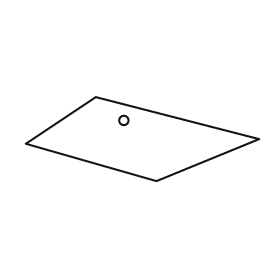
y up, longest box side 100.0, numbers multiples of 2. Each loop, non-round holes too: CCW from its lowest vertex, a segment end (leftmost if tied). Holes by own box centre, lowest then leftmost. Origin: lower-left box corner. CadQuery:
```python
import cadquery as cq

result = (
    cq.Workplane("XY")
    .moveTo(56.0, 0.0)
    .lineTo(100.0, 18.0)
    .lineTo(30.0, 36.0)
    .lineTo(0.0, 16.0)
    .close()
    .moveTo(42.0, 26.0)
    .circle(2.0)
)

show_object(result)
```